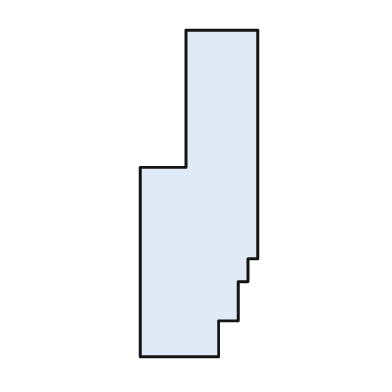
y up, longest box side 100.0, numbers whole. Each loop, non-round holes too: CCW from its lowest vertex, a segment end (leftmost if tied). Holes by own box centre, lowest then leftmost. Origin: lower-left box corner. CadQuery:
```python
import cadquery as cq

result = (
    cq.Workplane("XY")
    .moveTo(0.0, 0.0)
    .lineTo(24.0, 0.0)
    .lineTo(24.0, 11.0)
    .lineTo(30.0, 11.0)
    .lineTo(30.0, 23.0)
    .lineTo(33.0, 23.0)
    .lineTo(33.0, 30.0)
    .lineTo(36.0, 30.0)
    .lineTo(36.0, 100.0)
    .lineTo(14.0, 100.0)
    .lineTo(14.0, 58.0)
    .lineTo(0.0, 58.0)
    .close()
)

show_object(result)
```